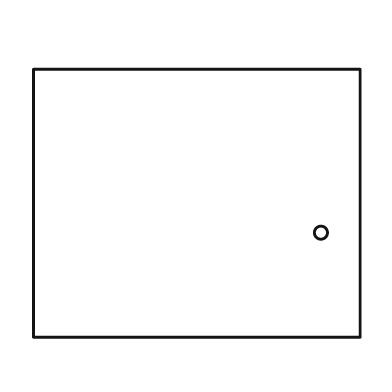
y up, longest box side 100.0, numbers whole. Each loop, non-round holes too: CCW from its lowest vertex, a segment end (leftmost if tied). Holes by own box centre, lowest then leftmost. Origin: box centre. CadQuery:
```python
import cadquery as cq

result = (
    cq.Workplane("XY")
    .moveTo(-50.0, -41.0)
    .lineTo(50.0, -41.0)
    .lineTo(50.0, 41.0)
    .lineTo(-50.0, 41.0)
    .close()
    .moveTo(38.0, -9.0)
    .circle(2.0)
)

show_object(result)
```